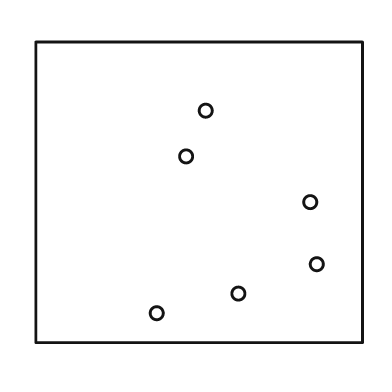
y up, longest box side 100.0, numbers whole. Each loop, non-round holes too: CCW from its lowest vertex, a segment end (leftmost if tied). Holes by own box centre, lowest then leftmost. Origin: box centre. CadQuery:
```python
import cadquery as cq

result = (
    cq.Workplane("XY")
    .moveTo(-50.0, -46.0)
    .lineTo(50.0, -46.0)
    .lineTo(50.0, 46.0)
    .lineTo(-50.0, 46.0)
    .close()
    .moveTo(-13.0, -37.0)
    .circle(2.0)
    .moveTo(12.0, -31.0)
    .circle(2.0)
    .moveTo(36.0, -22.0)
    .circle(2.0)
    .moveTo(34.0, -3.0)
    .circle(2.0)
    .moveTo(-4.0, 11.0)
    .circle(2.0)
    .moveTo(2.0, 25.0)
    .circle(2.0)
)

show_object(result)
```